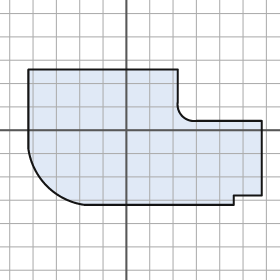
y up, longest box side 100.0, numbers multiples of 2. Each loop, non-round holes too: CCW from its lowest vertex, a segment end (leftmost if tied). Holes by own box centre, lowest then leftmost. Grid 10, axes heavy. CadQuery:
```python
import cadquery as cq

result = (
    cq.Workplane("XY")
    .moveTo(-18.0, -32.0)
    .lineTo(46.0, -32.0)
    .lineTo(46.0, -28.0)
    .lineTo(58.0, -28.0)
    .lineTo(58.0, 4.0)
    .lineTo(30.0, 4.0)
    .threePointArc((24.0, 6.0), (22.0, 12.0))
    .lineTo(22.0, 26.0)
    .lineTo(-42.0, 26.0)
    .lineTo(-42.0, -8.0)
    .threePointArc((-34.0, -24.0), (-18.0, -32.0))
    .close()
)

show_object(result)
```